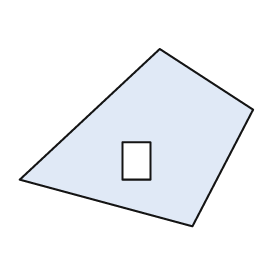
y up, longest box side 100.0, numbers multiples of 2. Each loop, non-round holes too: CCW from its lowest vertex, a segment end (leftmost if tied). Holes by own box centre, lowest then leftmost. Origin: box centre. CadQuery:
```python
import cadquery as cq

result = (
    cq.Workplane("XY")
    .moveTo(24.0, -38.0)
    .lineTo(50.0, 12.0)
    .lineTo(10.0, 38.0)
    .lineTo(-50.0, -18.0)
    .close()
    .moveTo(-6.0, -18.0)
    .lineTo(6.0, -18.0)
    .lineTo(6.0, -2.0)
    .lineTo(-6.0, -2.0)
    .close()
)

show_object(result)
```